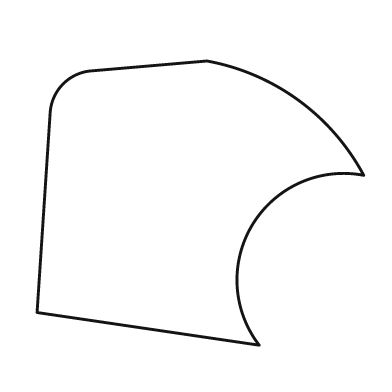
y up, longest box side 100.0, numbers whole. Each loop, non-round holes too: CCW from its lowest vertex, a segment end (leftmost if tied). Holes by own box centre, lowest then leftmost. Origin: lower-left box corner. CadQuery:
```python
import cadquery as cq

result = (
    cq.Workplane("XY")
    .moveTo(68.0, 0.0)
    .threePointArc((66.0, 37.0), (100.0, 52.0))
    .threePointArc((80.0, 75.0), (52.0, 87.0))
    .lineTo(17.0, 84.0)
    .threePointArc((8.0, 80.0), (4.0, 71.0))
    .lineTo(0.0, 10.0)
    .close()
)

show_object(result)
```